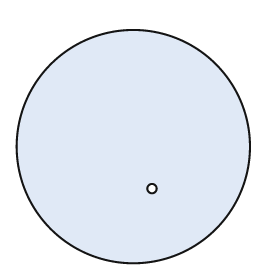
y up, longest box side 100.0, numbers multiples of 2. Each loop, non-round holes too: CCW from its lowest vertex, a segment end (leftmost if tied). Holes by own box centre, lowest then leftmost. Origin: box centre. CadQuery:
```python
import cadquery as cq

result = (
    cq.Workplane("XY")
    .moveTo(0.0, 0.0)
    .circle(50.0)
    .moveTo(8.0, -18.0)
    .circle(2.0)
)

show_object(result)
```